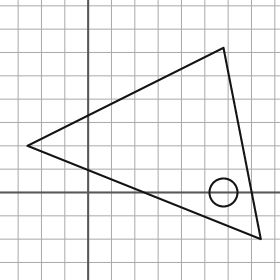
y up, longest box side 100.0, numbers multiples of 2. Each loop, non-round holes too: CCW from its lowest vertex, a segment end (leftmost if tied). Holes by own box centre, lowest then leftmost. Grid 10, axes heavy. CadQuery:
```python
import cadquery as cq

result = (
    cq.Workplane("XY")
    .moveTo(74.0, -20.0)
    .lineTo(58.0, 62.0)
    .lineTo(-26.0, 20.0)
    .close()
    .moveTo(58.0, 0.0)
    .circle(6.0)
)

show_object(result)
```